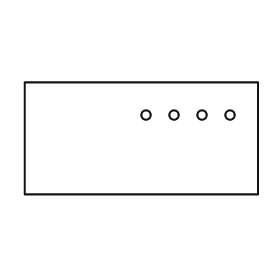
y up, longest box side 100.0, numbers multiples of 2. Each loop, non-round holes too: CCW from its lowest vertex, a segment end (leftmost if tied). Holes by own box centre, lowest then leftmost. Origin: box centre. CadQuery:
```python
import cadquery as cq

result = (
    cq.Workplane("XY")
    .moveTo(-50.0, -24.0)
    .lineTo(50.0, -24.0)
    .lineTo(50.0, 24.0)
    .lineTo(-50.0, 24.0)
    .close()
    .moveTo(2.0, 10.0)
    .circle(2.0)
    .moveTo(14.0, 10.0)
    .circle(2.0)
    .moveTo(26.0, 10.0)
    .circle(2.0)
    .moveTo(38.0, 10.0)
    .circle(2.0)
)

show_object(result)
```